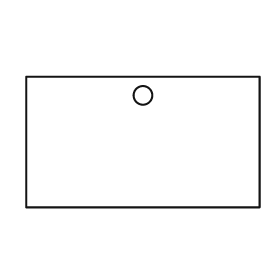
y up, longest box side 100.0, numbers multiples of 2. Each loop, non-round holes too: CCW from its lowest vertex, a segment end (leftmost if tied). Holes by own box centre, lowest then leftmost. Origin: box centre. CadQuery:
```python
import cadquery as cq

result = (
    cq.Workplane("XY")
    .moveTo(-50.0, -28.0)
    .lineTo(50.0, -28.0)
    .lineTo(50.0, 28.0)
    .lineTo(-50.0, 28.0)
    .close()
    .moveTo(0.0, 20.0)
    .circle(4.0)
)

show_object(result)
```